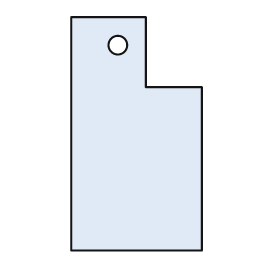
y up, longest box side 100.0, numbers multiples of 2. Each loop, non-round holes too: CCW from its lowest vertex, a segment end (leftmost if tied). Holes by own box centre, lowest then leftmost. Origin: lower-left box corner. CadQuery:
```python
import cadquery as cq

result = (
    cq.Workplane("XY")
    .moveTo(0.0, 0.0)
    .lineTo(56.0, 0.0)
    .lineTo(56.0, 70.0)
    .lineTo(32.0, 70.0)
    .lineTo(32.0, 100.0)
    .lineTo(0.0, 100.0)
    .close()
    .moveTo(20.0, 88.0)
    .circle(4.0)
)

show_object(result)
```